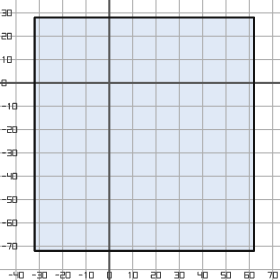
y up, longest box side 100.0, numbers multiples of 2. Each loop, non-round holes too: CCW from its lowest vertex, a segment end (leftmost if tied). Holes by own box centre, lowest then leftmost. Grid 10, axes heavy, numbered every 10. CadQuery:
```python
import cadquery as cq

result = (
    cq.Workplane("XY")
    .moveTo(-32.0, -72.0)
    .lineTo(62.0, -72.0)
    .lineTo(62.0, 28.0)
    .lineTo(-32.0, 28.0)
    .close()
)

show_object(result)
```